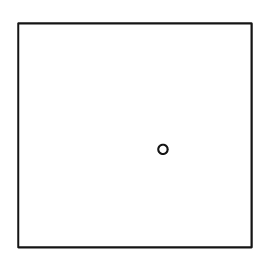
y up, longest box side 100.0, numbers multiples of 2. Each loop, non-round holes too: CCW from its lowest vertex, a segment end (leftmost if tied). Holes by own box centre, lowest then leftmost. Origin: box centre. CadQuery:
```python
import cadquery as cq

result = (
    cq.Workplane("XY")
    .moveTo(-50.0, -48.0)
    .lineTo(50.0, -48.0)
    .lineTo(50.0, 48.0)
    .lineTo(-50.0, 48.0)
    .close()
    .moveTo(12.0, -6.0)
    .circle(2.0)
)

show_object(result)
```